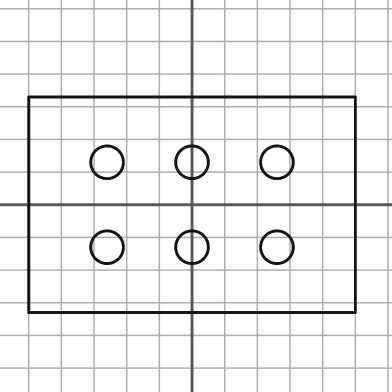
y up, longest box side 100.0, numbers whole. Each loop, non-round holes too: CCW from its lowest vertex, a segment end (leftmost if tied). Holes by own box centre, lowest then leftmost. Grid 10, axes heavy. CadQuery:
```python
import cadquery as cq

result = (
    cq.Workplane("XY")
    .moveTo(-50.0, -33.0)
    .lineTo(50.0, -33.0)
    .lineTo(50.0, 33.0)
    .lineTo(-50.0, 33.0)
    .close()
    .moveTo(-26.0, -13.0)
    .circle(5.0)
    .moveTo(0.0, -13.0)
    .circle(5.0)
    .moveTo(26.0, -13.0)
    .circle(5.0)
    .moveTo(-26.0, 13.0)
    .circle(5.0)
    .moveTo(0.0, 13.0)
    .circle(5.0)
    .moveTo(26.0, 13.0)
    .circle(5.0)
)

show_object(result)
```